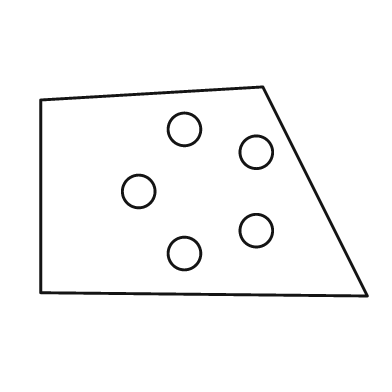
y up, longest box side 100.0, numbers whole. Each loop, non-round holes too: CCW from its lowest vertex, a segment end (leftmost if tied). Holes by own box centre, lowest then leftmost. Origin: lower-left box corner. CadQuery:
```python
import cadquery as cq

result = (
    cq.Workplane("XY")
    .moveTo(100.0, 0.0)
    .lineTo(68.0, 64.0)
    .lineTo(0.0, 60.0)
    .lineTo(0.0, 1.0)
    .close()
    .moveTo(44.0, 13.0)
    .circle(5.0)
    .moveTo(66.0, 20.0)
    .circle(5.0)
    .moveTo(30.0, 32.0)
    .circle(5.0)
    .moveTo(66.0, 44.0)
    .circle(5.0)
    .moveTo(44.0, 51.0)
    .circle(5.0)
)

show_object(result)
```